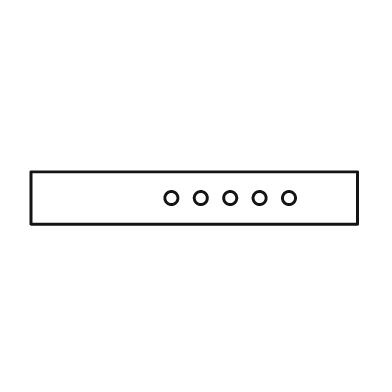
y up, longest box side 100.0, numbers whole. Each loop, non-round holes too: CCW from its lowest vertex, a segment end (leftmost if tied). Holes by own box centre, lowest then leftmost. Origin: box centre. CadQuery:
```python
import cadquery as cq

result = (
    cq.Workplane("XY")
    .moveTo(-50.0, -8.0)
    .lineTo(50.0, -8.0)
    .lineTo(50.0, 8.0)
    .lineTo(-50.0, 8.0)
    .close()
    .moveTo(-7.0, 0.0)
    .circle(2.0)
    .moveTo(2.0, 0.0)
    .circle(2.0)
    .moveTo(11.0, 0.0)
    .circle(2.0)
    .moveTo(20.0, 0.0)
    .circle(2.0)
    .moveTo(29.0, 0.0)
    .circle(2.0)
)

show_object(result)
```